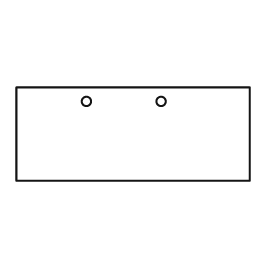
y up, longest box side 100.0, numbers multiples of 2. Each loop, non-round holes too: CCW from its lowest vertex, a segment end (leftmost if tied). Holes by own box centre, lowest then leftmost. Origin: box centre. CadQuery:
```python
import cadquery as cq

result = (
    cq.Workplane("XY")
    .moveTo(-50.0, -20.0)
    .lineTo(50.0, -20.0)
    .lineTo(50.0, 20.0)
    .lineTo(-50.0, 20.0)
    .close()
    .moveTo(-20.0, 14.0)
    .circle(2.0)
    .moveTo(12.0, 14.0)
    .circle(2.0)
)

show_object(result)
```